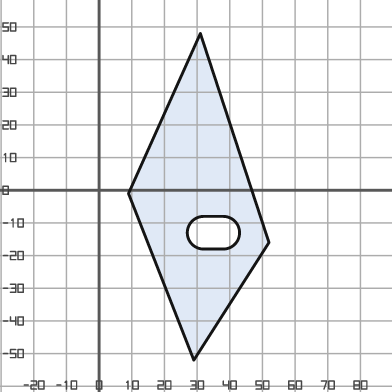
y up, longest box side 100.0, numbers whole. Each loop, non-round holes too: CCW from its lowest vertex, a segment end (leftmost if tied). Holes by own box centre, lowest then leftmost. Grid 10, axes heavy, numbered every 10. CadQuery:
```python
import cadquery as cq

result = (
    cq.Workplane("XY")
    .moveTo(29.0, -52.0)
    .lineTo(52.0, -16.0)
    .lineTo(31.0, 48.0)
    .lineTo(9.0, -1.0)
    .close()
    .moveTo(32.0, -18.0)
    .lineTo(38.0, -18.0)
    .threePointArc((43.0, -13.0), (38.0, -8.0))
    .lineTo(32.0, -8.0)
    .threePointArc((27.0, -13.0), (32.0, -18.0))
    .close()
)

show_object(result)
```